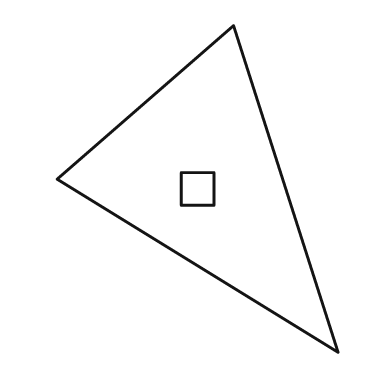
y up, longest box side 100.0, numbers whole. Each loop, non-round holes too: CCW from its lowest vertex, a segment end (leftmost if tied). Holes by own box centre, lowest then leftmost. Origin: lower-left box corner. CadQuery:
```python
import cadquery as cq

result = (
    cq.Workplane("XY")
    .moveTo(86.0, 0.0)
    .lineTo(54.0, 100.0)
    .lineTo(0.0, 53.0)
    .close()
    .moveTo(38.0, 45.0)
    .lineTo(48.0, 45.0)
    .lineTo(48.0, 55.0)
    .lineTo(38.0, 55.0)
    .close()
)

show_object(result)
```